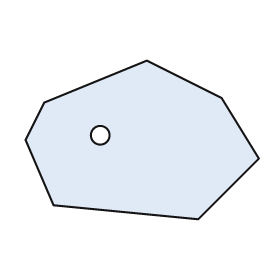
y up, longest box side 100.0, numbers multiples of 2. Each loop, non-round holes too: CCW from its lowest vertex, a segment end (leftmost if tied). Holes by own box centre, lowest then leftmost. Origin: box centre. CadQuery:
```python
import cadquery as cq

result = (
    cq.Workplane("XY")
    .moveTo(24.0, -34.0)
    .lineTo(50.0, -8.0)
    .lineTo(34.0, 18.0)
    .lineTo(2.0, 34.0)
    .lineTo(-42.0, 16.0)
    .lineTo(-50.0, 0.0)
    .lineTo(-38.0, -28.0)
    .close()
    .moveTo(-18.0, 2.0)
    .circle(4.0)
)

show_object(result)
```